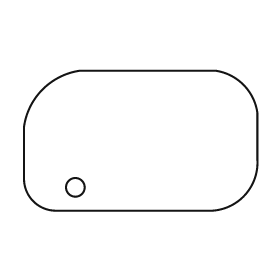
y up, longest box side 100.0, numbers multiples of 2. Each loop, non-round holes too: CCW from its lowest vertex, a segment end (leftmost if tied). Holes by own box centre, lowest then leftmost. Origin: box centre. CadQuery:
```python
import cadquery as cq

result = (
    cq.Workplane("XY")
    .moveTo(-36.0, -30.0)
    .lineTo(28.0, -30.0)
    .threePointArc((44.0, -24.0), (50.0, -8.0))
    .lineTo(50.0, 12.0)
    .threePointArc((44.0, 24.0), (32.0, 30.0))
    .lineTo(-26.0, 30.0)
    .threePointArc((-42.0, 22.0), (-50.0, 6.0))
    .lineTo(-50.0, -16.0)
    .threePointArc((-46.0, -26.0), (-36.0, -30.0))
    .close()
    .moveTo(-28.0, -20.0)
    .circle(4.0)
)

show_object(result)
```